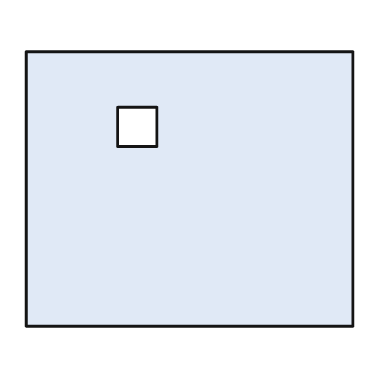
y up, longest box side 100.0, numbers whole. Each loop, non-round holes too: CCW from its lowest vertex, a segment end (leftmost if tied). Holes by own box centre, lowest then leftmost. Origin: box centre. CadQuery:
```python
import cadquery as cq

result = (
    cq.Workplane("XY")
    .moveTo(-50.0, -42.0)
    .lineTo(50.0, -42.0)
    .lineTo(50.0, 42.0)
    .lineTo(-50.0, 42.0)
    .close()
    .moveTo(-22.0, 13.0)
    .lineTo(-10.0, 13.0)
    .lineTo(-10.0, 25.0)
    .lineTo(-22.0, 25.0)
    .close()
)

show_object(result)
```